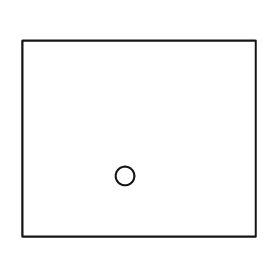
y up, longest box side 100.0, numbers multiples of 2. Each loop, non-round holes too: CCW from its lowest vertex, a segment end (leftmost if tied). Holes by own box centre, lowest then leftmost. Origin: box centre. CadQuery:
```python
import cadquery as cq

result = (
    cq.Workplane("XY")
    .moveTo(-50.0, -42.0)
    .lineTo(50.0, -42.0)
    .lineTo(50.0, 42.0)
    .lineTo(-50.0, 42.0)
    .close()
    .moveTo(-6.0, -16.0)
    .circle(4.0)
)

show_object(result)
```